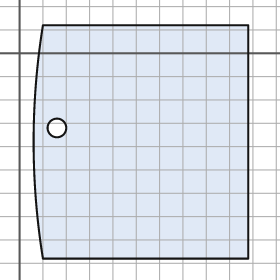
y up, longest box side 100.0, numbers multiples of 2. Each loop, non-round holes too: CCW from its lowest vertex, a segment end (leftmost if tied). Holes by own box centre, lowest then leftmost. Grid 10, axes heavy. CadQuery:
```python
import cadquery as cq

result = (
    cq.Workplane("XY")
    .moveTo(10.0, -88.0)
    .lineTo(98.0, -88.0)
    .lineTo(98.0, 12.0)
    .lineTo(10.0, 12.0)
    .threePointArc((6.0, -38.0), (10.0, -88.0))
    .close()
    .moveTo(16.0, -32.0)
    .circle(4.0)
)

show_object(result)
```